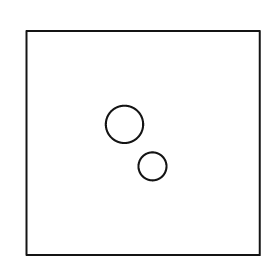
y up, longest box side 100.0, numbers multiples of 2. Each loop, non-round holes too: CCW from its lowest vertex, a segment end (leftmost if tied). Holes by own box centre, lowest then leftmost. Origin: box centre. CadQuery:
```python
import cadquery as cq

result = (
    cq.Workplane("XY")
    .moveTo(-50.0, -48.0)
    .lineTo(50.0, -48.0)
    .lineTo(50.0, 48.0)
    .lineTo(-50.0, 48.0)
    .close()
    .moveTo(4.0, -10.0)
    .circle(6.0)
    .moveTo(-8.0, 8.0)
    .circle(8.0)
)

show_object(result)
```